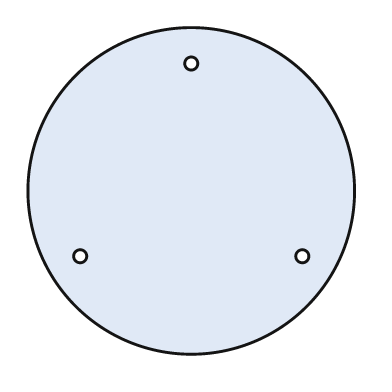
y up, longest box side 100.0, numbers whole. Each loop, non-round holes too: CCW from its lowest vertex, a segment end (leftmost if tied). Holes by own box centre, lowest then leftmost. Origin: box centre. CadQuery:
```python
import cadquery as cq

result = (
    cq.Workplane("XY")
    .moveTo(0.0, 0.0)
    .circle(50.0)
    .moveTo(-34.0, -20.0)
    .circle(2.0)
    .moveTo(34.0, -20.0)
    .circle(2.0)
    .moveTo(0.0, 39.0)
    .circle(2.0)
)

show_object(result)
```